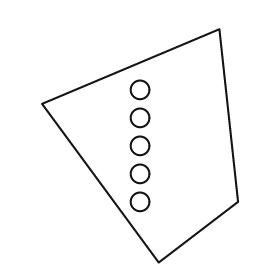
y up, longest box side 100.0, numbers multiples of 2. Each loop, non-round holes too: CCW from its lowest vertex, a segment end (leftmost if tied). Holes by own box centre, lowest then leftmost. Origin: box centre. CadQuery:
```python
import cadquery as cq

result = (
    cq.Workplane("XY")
    .moveTo(8.0, -50.0)
    .lineTo(42.0, -24.0)
    .lineTo(34.0, 50.0)
    .lineTo(-42.0, 18.0)
    .close()
    .moveTo(0.0, -24.0)
    .circle(4.0)
    .moveTo(0.0, -12.0)
    .circle(4.0)
    .moveTo(0.0, 0.0)
    .circle(4.0)
    .moveTo(0.0, 12.0)
    .circle(4.0)
    .moveTo(0.0, 24.0)
    .circle(4.0)
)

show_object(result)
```